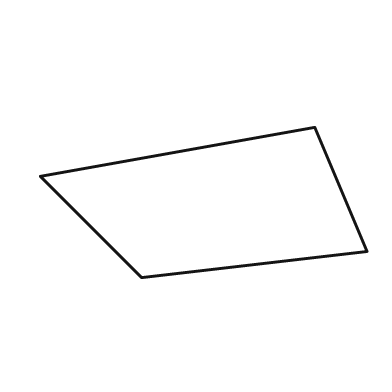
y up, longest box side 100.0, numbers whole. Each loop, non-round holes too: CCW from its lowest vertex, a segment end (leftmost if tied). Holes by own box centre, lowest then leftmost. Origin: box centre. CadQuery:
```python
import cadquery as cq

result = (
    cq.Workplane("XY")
    .moveTo(-19.0, -23.0)
    .lineTo(50.0, -15.0)
    .lineTo(34.0, 23.0)
    .lineTo(-50.0, 8.0)
    .close()
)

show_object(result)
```